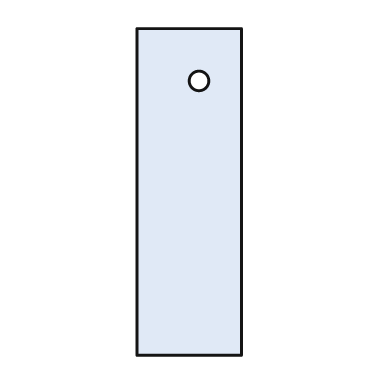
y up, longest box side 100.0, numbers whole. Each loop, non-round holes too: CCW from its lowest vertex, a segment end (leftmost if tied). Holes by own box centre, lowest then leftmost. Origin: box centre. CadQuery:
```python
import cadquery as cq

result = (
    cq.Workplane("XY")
    .moveTo(-16.0, -50.0)
    .lineTo(16.0, -50.0)
    .lineTo(16.0, 50.0)
    .lineTo(-16.0, 50.0)
    .close()
    .moveTo(3.0, 34.0)
    .circle(3.0)
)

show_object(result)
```